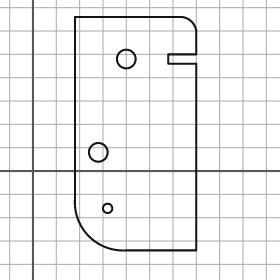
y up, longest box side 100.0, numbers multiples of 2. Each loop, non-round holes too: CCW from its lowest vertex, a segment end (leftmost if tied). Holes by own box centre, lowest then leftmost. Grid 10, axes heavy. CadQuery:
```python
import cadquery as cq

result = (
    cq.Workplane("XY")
    .moveTo(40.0, -34.0)
    .lineTo(70.0, -34.0)
    .lineTo(70.0, 46.0)
    .lineTo(58.0, 46.0)
    .lineTo(58.0, 50.0)
    .lineTo(70.0, 50.0)
    .lineTo(70.0, 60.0)
    .threePointArc((68.0, 64.0), (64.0, 66.0))
    .lineTo(18.0, 66.0)
    .lineTo(18.0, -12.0)
    .threePointArc((24.0, -28.0), (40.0, -34.0))
    .close()
    .moveTo(32.0, -16.0)
    .circle(2.0)
    .moveTo(28.0, 8.0)
    .circle(4.0)
    .moveTo(40.0, 48.0)
    .circle(4.0)
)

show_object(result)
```